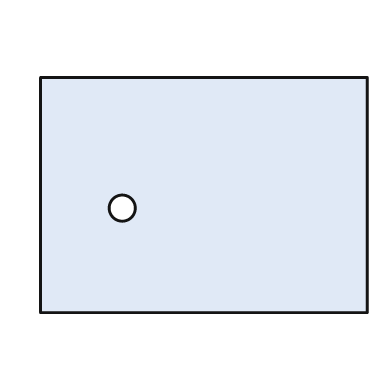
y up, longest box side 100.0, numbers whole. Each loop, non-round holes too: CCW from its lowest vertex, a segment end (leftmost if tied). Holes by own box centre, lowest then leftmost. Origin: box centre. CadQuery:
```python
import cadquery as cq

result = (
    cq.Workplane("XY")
    .moveTo(-50.0, -36.0)
    .lineTo(50.0, -36.0)
    .lineTo(50.0, 36.0)
    .lineTo(-50.0, 36.0)
    .close()
    .moveTo(-25.0, -4.0)
    .circle(4.0)
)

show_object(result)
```